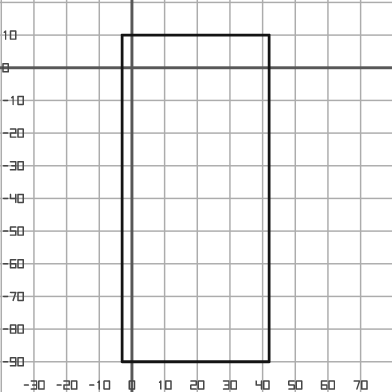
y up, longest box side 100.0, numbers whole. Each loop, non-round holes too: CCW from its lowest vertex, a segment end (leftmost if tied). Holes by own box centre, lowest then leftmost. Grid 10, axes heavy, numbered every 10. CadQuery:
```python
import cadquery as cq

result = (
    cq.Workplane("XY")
    .moveTo(-3.0, -90.0)
    .lineTo(42.0, -90.0)
    .lineTo(42.0, 10.0)
    .lineTo(-3.0, 10.0)
    .close()
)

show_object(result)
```